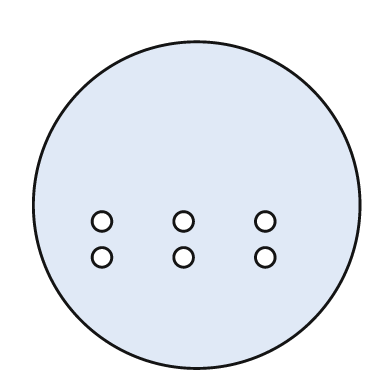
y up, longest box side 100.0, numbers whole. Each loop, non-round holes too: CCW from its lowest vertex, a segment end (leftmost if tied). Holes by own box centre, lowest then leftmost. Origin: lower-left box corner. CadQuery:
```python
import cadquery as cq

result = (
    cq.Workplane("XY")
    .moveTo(50.0, 50.0)
    .circle(50.0)
    .moveTo(21.0, 34.0)
    .circle(3.0)
    .moveTo(46.0, 34.0)
    .circle(3.0)
    .moveTo(71.0, 34.0)
    .circle(3.0)
    .moveTo(21.0, 45.0)
    .circle(3.0)
    .moveTo(46.0, 45.0)
    .circle(3.0)
    .moveTo(71.0, 45.0)
    .circle(3.0)
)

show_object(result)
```